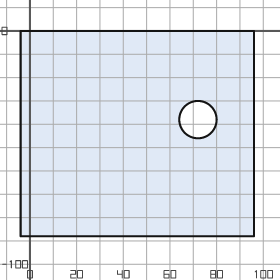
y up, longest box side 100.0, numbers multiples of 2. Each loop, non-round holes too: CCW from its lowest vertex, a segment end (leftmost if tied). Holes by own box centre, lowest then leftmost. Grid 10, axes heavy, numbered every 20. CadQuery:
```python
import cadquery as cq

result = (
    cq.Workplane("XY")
    .moveTo(-4.0, -88.0)
    .lineTo(96.0, -88.0)
    .lineTo(96.0, 0.0)
    .lineTo(-4.0, 0.0)
    .close()
    .moveTo(72.0, -38.0)
    .circle(8.0)
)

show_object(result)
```